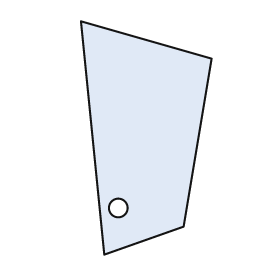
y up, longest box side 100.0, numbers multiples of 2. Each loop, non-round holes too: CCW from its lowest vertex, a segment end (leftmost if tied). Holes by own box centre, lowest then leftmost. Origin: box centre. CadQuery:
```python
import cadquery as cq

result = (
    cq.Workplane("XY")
    .moveTo(-18.0, -50.0)
    .lineTo(16.0, -38.0)
    .lineTo(28.0, 34.0)
    .lineTo(-28.0, 50.0)
    .close()
    .moveTo(-12.0, -30.0)
    .circle(4.0)
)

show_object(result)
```